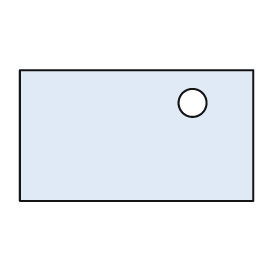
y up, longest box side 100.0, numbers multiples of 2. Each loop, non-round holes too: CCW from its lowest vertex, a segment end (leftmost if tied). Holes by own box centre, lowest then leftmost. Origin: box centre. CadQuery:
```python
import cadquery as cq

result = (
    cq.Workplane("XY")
    .moveTo(-50.0, -28.0)
    .lineTo(50.0, -28.0)
    .lineTo(50.0, 28.0)
    .lineTo(-50.0, 28.0)
    .close()
    .moveTo(24.0, 14.0)
    .circle(6.0)
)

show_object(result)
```